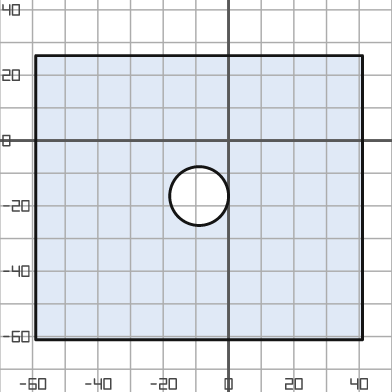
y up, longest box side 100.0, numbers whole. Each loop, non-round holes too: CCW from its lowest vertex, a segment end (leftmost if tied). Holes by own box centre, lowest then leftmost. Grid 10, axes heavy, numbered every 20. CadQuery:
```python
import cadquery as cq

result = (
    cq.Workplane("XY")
    .moveTo(-59.0, -61.0)
    .lineTo(41.0, -61.0)
    .lineTo(41.0, 26.0)
    .lineTo(-59.0, 26.0)
    .close()
    .moveTo(-9.0, -17.0)
    .circle(9.0)
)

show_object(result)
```